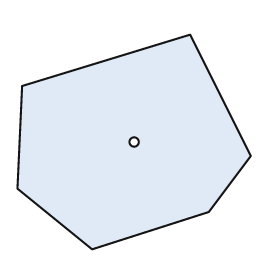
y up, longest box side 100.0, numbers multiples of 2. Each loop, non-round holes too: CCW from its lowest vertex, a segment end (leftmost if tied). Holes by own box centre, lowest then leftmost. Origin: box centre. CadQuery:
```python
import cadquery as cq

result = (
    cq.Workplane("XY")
    .moveTo(-18.0, -46.0)
    .lineTo(32.0, -30.0)
    .lineTo(50.0, -6.0)
    .lineTo(24.0, 46.0)
    .lineTo(-48.0, 24.0)
    .lineTo(-50.0, -20.0)
    .close()
    .moveTo(0.0, 0.0)
    .circle(2.0)
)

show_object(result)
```